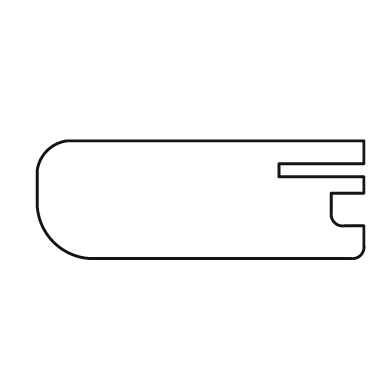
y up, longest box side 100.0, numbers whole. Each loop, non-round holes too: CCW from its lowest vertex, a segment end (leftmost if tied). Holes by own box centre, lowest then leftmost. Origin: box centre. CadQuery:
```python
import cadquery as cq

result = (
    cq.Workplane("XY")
    .moveTo(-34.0, -18.0)
    .lineTo(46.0, -18.0)
    .threePointArc((49.0, -17.0), (50.0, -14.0))
    .lineTo(50.0, -8.0)
    .lineTo(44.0, -8.0)
    .threePointArc((41.0, -7.0), (40.0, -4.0))
    .lineTo(40.0, 2.0)
    .lineTo(50.0, 2.0)
    .lineTo(50.0, 7.0)
    .lineTo(24.0, 7.0)
    .lineTo(24.0, 11.0)
    .lineTo(50.0, 11.0)
    .lineTo(50.0, 18.0)
    .lineTo(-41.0, 18.0)
    .threePointArc((-47.0, 15.0), (-50.0, 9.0))
    .lineTo(-50.0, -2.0)
    .threePointArc((-45.0, -13.0), (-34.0, -18.0))
    .close()
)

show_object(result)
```